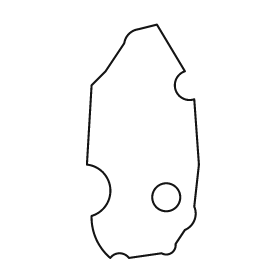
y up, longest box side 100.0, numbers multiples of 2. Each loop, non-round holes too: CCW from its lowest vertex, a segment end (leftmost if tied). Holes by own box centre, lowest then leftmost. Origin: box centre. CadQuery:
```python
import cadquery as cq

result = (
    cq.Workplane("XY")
    .moveTo(-14.0, -50.0)
    .threePointArc((-10.0, -48.0), (-6.0, -50.0))
    .lineTo(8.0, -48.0)
    .threePointArc((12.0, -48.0), (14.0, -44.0))
    .lineTo(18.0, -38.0)
    .threePointArc((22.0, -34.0), (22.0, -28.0))
    .lineTo(24.0, -10.0)
    .lineTo(22.0, 18.0)
    .threePointArc((14.0, 22.0), (18.0, 30.0))
    .lineTo(6.0, 50.0)
    .lineTo(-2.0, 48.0)
    .threePointArc((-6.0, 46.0), (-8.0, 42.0))
    .lineTo(-16.0, 30.0)
    .lineTo(-22.0, 24.0)
    .lineTo(-24.0, -10.0)
    .threePointArc((-14.0, -20.0), (-22.0, -32.0))
    .threePointArc((-20.0, -42.0), (-14.0, -50.0))
    .close()
    .moveTo(10.0, -24.0)
    .circle(6.0)
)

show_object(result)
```